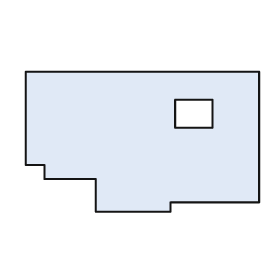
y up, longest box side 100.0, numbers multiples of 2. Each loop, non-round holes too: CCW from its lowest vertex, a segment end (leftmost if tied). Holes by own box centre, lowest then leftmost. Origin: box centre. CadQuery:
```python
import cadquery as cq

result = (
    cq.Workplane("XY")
    .moveTo(-20.0, -30.0)
    .lineTo(12.0, -30.0)
    .lineTo(12.0, -26.0)
    .lineTo(50.0, -26.0)
    .lineTo(50.0, 30.0)
    .lineTo(-50.0, 30.0)
    .lineTo(-50.0, -10.0)
    .lineTo(-42.0, -10.0)
    .lineTo(-42.0, -16.0)
    .lineTo(-20.0, -16.0)
    .close()
    .moveTo(14.0, 6.0)
    .lineTo(30.0, 6.0)
    .lineTo(30.0, 18.0)
    .lineTo(14.0, 18.0)
    .close()
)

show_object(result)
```